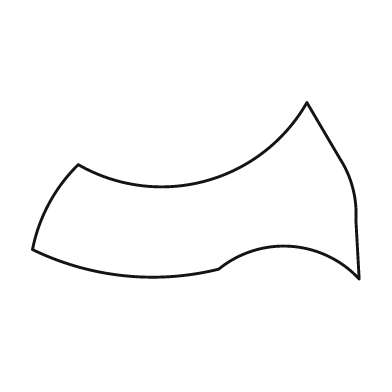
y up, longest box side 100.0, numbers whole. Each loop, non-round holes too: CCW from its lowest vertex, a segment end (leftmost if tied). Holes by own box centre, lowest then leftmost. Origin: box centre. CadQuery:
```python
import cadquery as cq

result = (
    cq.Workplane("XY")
    .moveTo(50.0, -27.0)
    .lineTo(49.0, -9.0)
    .threePointArc((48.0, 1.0), (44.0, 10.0))
    .lineTo(34.0, 27.0)
    .threePointArc((3.0, 3.0), (-36.0, 8.0))
    .threePointArc((-45.0, -4.0), (-50.0, -18.0))
    .threePointArc((-22.0, -26.0), (7.0, -24.0))
    .threePointArc((29.0, -17.0), (50.0, -27.0))
    .close()
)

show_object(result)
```